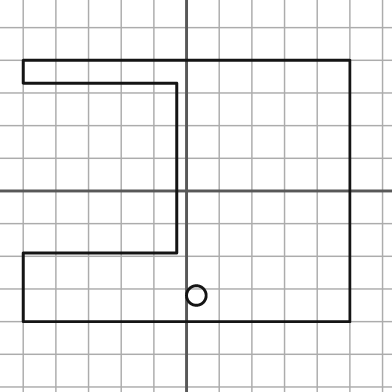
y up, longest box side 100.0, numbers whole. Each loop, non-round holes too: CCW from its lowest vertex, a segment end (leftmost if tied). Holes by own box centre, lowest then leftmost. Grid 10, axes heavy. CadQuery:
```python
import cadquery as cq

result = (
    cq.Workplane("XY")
    .moveTo(-50.0, -40.0)
    .lineTo(50.0, -40.0)
    .lineTo(50.0, 40.0)
    .lineTo(-50.0, 40.0)
    .lineTo(-50.0, 33.0)
    .lineTo(-3.0, 33.0)
    .lineTo(-3.0, -19.0)
    .lineTo(-50.0, -19.0)
    .close()
    .moveTo(3.0, -32.0)
    .circle(3.0)
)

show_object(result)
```